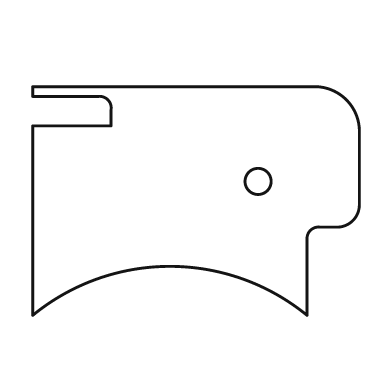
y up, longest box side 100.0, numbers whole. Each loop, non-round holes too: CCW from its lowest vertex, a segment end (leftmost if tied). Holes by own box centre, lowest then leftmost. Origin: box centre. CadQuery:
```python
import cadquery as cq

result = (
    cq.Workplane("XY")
    .moveTo(-50.0, -35.0)
    .threePointArc((-8.0, -20.0), (34.0, -35.0))
    .lineTo(34.0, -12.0)
    .threePointArc((35.0, -9.0), (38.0, -8.0))
    .lineTo(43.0, -8.0)
    .threePointArc((48.0, -6.0), (50.0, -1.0))
    .lineTo(50.0, 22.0)
    .threePointArc((46.0, 31.0), (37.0, 35.0))
    .lineTo(-50.0, 35.0)
    .lineTo(-50.0, 32.0)
    .lineTo(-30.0, 32.0)
    .threePointArc((-27.0, 31.0), (-26.0, 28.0))
    .lineTo(-26.0, 23.0)
    .lineTo(-50.0, 23.0)
    .close()
    .moveTo(19.0, 6.0)
    .circle(4.0)
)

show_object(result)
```